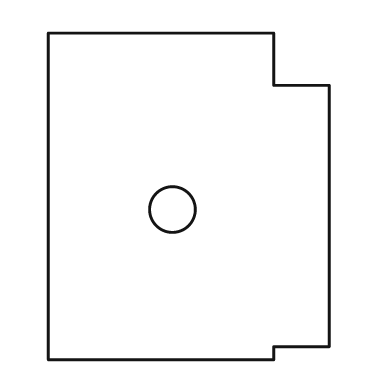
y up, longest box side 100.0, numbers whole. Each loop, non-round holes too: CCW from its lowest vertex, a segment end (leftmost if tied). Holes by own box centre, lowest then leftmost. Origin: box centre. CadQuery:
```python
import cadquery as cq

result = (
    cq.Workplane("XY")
    .moveTo(-43.0, -50.0)
    .lineTo(26.0, -50.0)
    .lineTo(26.0, -46.0)
    .lineTo(43.0, -46.0)
    .lineTo(43.0, 34.0)
    .lineTo(26.0, 34.0)
    .lineTo(26.0, 50.0)
    .lineTo(-43.0, 50.0)
    .close()
    .moveTo(-5.0, -4.0)
    .circle(7.0)
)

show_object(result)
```